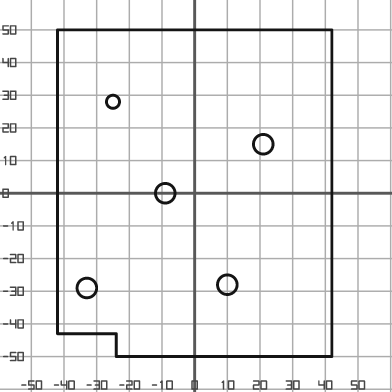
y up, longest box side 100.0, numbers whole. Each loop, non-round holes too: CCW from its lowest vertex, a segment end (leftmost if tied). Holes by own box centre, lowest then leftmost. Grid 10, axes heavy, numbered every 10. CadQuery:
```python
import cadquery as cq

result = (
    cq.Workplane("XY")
    .moveTo(-24.0, -50.0)
    .lineTo(42.0, -50.0)
    .lineTo(42.0, 50.0)
    .lineTo(-42.0, 50.0)
    .lineTo(-42.0, -43.0)
    .lineTo(-24.0, -43.0)
    .close()
    .moveTo(-33.0, -29.0)
    .circle(3.0)
    .moveTo(10.0, -28.0)
    .circle(3.0)
    .moveTo(-9.0, 0.0)
    .circle(3.0)
    .moveTo(21.0, 15.0)
    .circle(3.0)
    .moveTo(-25.0, 28.0)
    .circle(2.0)
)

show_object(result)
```